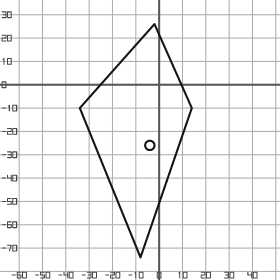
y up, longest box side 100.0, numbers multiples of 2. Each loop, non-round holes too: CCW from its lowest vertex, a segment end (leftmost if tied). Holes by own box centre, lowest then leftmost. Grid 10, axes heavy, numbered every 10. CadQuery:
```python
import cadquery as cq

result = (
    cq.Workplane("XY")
    .moveTo(-8.0, -74.0)
    .lineTo(14.0, -10.0)
    .lineTo(-2.0, 26.0)
    .lineTo(-34.0, -10.0)
    .close()
    .moveTo(-4.0, -26.0)
    .circle(2.0)
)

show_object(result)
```